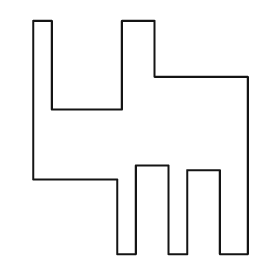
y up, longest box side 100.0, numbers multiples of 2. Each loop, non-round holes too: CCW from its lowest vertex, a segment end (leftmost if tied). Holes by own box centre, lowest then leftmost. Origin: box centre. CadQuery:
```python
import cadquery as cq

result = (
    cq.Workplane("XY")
    .moveTo(-10.0, -50.0)
    .lineTo(-2.0, -50.0)
    .lineTo(-2.0, -12.0)
    .lineTo(12.0, -12.0)
    .lineTo(12.0, -50.0)
    .lineTo(20.0, -50.0)
    .lineTo(20.0, -14.0)
    .lineTo(34.0, -14.0)
    .lineTo(34.0, -50.0)
    .lineTo(46.0, -50.0)
    .lineTo(46.0, 26.0)
    .lineTo(6.0, 26.0)
    .lineTo(6.0, 50.0)
    .lineTo(-8.0, 50.0)
    .lineTo(-8.0, 12.0)
    .lineTo(-38.0, 12.0)
    .lineTo(-38.0, 50.0)
    .lineTo(-46.0, 50.0)
    .lineTo(-46.0, -18.0)
    .lineTo(-10.0, -18.0)
    .close()
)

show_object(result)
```